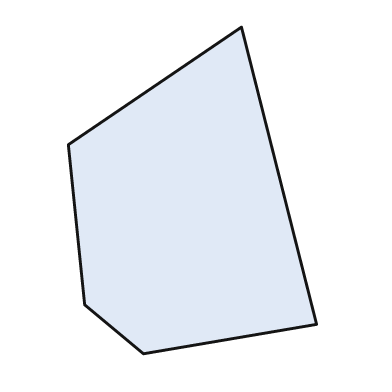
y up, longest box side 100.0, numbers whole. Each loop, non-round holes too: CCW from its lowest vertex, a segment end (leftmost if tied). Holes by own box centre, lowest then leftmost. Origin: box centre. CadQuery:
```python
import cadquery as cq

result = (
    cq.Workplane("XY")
    .moveTo(-15.0, -50.0)
    .lineTo(38.0, -41.0)
    .lineTo(15.0, 50.0)
    .lineTo(-38.0, 14.0)
    .lineTo(-33.0, -35.0)
    .close()
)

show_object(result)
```